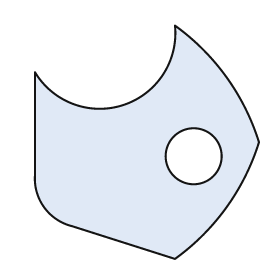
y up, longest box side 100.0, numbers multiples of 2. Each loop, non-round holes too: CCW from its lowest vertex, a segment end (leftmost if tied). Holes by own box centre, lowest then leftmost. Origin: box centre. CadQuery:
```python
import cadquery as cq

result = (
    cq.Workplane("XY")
    .moveTo(12.0, -50.0)
    .threePointArc((34.0, -28.0), (48.0, 0.0))
    .threePointArc((34.0, 28.0), (12.0, 50.0))
    .threePointArc((-10.0, 16.0), (-48.0, 30.0))
    .lineTo(-48.0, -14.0)
    .threePointArc((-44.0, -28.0), (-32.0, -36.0))
    .close()
    .moveTo(20.0, -6.0)
    .circle(12.0)
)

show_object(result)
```